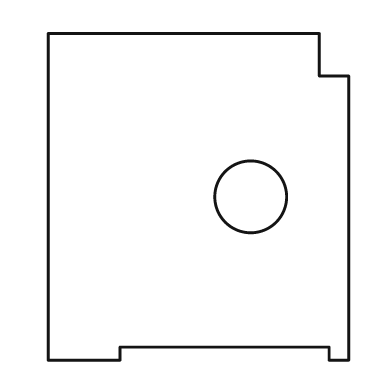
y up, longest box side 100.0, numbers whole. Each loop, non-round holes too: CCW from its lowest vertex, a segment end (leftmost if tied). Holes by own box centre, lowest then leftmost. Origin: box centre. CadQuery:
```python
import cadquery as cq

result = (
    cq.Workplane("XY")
    .moveTo(-46.0, -50.0)
    .lineTo(-24.0, -50.0)
    .lineTo(-24.0, -46.0)
    .lineTo(40.0, -46.0)
    .lineTo(40.0, -50.0)
    .lineTo(46.0, -50.0)
    .lineTo(46.0, 37.0)
    .lineTo(37.0, 37.0)
    .lineTo(37.0, 50.0)
    .lineTo(-46.0, 50.0)
    .close()
    .moveTo(16.0, 0.0)
    .circle(11.0)
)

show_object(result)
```